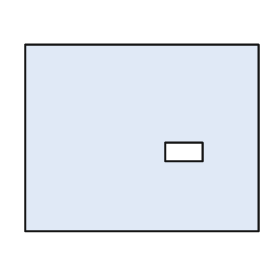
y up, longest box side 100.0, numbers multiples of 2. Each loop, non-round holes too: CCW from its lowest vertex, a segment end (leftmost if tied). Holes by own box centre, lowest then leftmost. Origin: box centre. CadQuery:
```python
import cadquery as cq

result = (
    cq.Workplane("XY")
    .moveTo(-50.0, -40.0)
    .lineTo(50.0, -40.0)
    .lineTo(50.0, 40.0)
    .lineTo(-50.0, 40.0)
    .close()
    .moveTo(10.0, -10.0)
    .lineTo(26.0, -10.0)
    .lineTo(26.0, -2.0)
    .lineTo(10.0, -2.0)
    .close()
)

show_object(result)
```